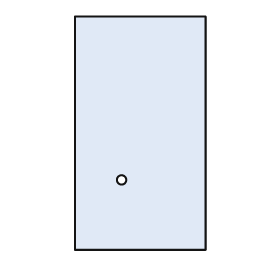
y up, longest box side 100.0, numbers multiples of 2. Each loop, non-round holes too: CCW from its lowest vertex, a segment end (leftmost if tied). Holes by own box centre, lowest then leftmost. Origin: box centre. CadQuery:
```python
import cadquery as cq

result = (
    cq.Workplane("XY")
    .moveTo(-28.0, -50.0)
    .lineTo(28.0, -50.0)
    .lineTo(28.0, 50.0)
    .lineTo(-28.0, 50.0)
    .close()
    .moveTo(-8.0, -20.0)
    .circle(2.0)
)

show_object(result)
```